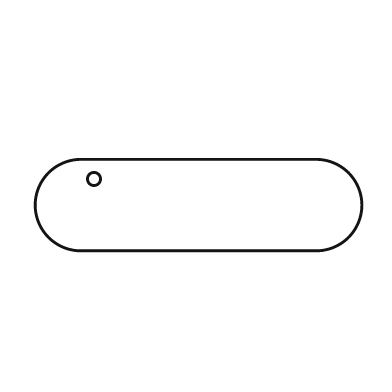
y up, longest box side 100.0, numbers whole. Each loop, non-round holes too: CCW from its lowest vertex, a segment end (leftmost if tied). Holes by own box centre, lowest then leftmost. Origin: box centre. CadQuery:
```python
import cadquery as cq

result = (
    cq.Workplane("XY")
    .moveTo(-36.0, -14.0)
    .lineTo(36.0, -14.0)
    .threePointArc((50.0, 0.0), (36.0, 14.0))
    .lineTo(-36.0, 14.0)
    .threePointArc((-50.0, 0.0), (-36.0, -14.0))
    .close()
    .moveTo(-32.0, 8.0)
    .circle(2.0)
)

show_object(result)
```